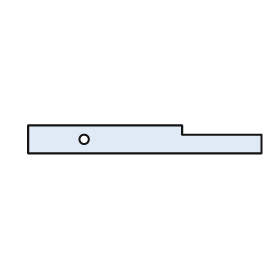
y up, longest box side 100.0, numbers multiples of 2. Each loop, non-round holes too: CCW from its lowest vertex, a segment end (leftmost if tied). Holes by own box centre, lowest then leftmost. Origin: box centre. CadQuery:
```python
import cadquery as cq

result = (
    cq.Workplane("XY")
    .moveTo(-50.0, -6.0)
    .lineTo(50.0, -6.0)
    .lineTo(50.0, 2.0)
    .lineTo(16.0, 2.0)
    .lineTo(16.0, 6.0)
    .lineTo(-50.0, 6.0)
    .close()
    .moveTo(-26.0, 0.0)
    .circle(2.0)
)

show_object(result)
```